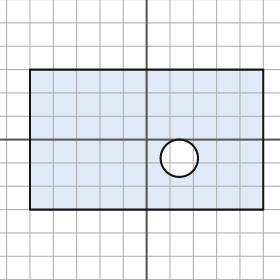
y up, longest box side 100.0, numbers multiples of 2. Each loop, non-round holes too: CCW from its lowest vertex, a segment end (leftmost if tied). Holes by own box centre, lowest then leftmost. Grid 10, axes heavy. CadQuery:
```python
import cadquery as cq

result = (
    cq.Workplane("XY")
    .moveTo(-50.0, -30.0)
    .lineTo(50.0, -30.0)
    .lineTo(50.0, 30.0)
    .lineTo(-50.0, 30.0)
    .close()
    .moveTo(14.0, -8.0)
    .circle(8.0)
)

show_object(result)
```